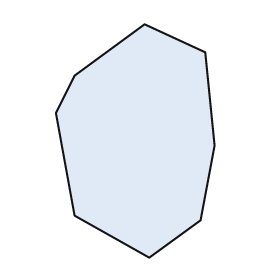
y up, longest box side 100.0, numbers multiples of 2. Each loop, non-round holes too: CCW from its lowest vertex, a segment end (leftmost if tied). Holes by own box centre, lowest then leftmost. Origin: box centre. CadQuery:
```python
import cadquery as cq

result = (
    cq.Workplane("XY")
    .moveTo(6.0, -50.0)
    .lineTo(28.0, -34.0)
    .lineTo(34.0, -2.0)
    .lineTo(30.0, 38.0)
    .lineTo(4.0, 50.0)
    .lineTo(-26.0, 28.0)
    .lineTo(-34.0, 12.0)
    .lineTo(-26.0, -32.0)
    .close()
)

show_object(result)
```